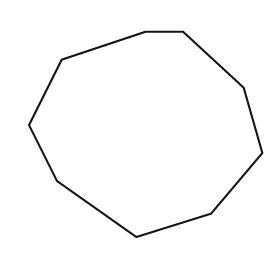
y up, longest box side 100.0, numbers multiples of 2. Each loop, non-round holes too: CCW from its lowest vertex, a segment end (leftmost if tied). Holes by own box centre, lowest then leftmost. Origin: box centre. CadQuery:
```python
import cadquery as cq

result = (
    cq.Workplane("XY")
    .moveTo(-4.0, -44.0)
    .lineTo(28.0, -34.0)
    .lineTo(50.0, -8.0)
    .lineTo(42.0, 20.0)
    .lineTo(16.0, 44.0)
    .lineTo(0.0, 44.0)
    .lineTo(-36.0, 32.0)
    .lineTo(-50.0, 4.0)
    .lineTo(-38.0, -20.0)
    .close()
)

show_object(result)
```